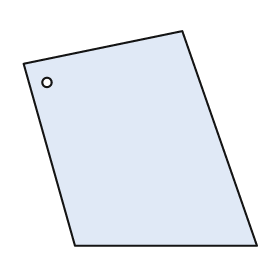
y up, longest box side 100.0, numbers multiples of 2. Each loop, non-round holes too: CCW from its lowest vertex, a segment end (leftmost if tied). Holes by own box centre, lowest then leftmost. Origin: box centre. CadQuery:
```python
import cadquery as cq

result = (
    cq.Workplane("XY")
    .moveTo(-28.0, -46.0)
    .lineTo(50.0, -46.0)
    .lineTo(18.0, 46.0)
    .lineTo(-50.0, 32.0)
    .close()
    .moveTo(-40.0, 24.0)
    .circle(2.0)
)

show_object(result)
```